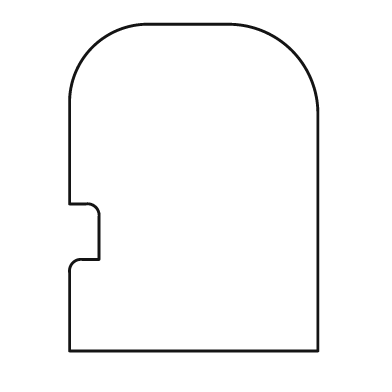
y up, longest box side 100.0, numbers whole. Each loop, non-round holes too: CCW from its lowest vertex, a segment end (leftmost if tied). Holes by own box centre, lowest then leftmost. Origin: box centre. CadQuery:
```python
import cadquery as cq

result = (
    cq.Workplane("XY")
    .moveTo(-38.0, -50.0)
    .lineTo(38.0, -50.0)
    .lineTo(38.0, 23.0)
    .threePointArc((30.0, 42.0), (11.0, 50.0))
    .lineTo(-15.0, 50.0)
    .threePointArc((-31.0, 43.0), (-38.0, 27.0))
    .lineTo(-38.0, -5.0)
    .lineTo(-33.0, -5.0)
    .threePointArc((-30.0, -6.0), (-29.0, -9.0))
    .lineTo(-29.0, -22.0)
    .lineTo(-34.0, -22.0)
    .threePointArc((-37.0, -23.0), (-38.0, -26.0))
    .close()
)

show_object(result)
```